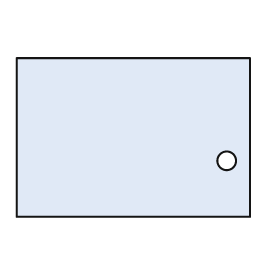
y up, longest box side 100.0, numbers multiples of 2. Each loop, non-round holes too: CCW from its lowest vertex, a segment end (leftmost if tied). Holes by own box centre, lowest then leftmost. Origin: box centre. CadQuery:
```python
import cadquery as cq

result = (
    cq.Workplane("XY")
    .moveTo(-50.0, -34.0)
    .lineTo(50.0, -34.0)
    .lineTo(50.0, 34.0)
    .lineTo(-50.0, 34.0)
    .close()
    .moveTo(40.0, -10.0)
    .circle(4.0)
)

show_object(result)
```